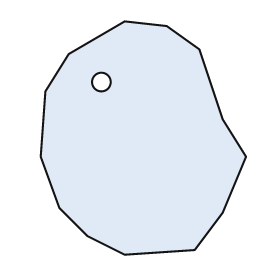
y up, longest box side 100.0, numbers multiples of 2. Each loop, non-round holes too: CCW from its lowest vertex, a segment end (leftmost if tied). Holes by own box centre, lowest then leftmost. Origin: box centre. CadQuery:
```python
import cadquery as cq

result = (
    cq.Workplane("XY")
    .moveTo(-8.0, -50.0)
    .lineTo(22.0, -48.0)
    .lineTo(34.0, -32.0)
    .lineTo(44.0, -8.0)
    .lineTo(34.0, 8.0)
    .lineTo(24.0, 38.0)
    .lineTo(10.0, 48.0)
    .lineTo(-8.0, 50.0)
    .lineTo(-32.0, 36.0)
    .lineTo(-42.0, 20.0)
    .lineTo(-44.0, -8.0)
    .lineTo(-36.0, -30.0)
    .lineTo(-24.0, -42.0)
    .close()
    .moveTo(-18.0, 24.0)
    .circle(4.0)
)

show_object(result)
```